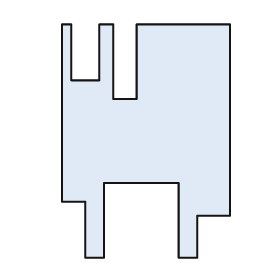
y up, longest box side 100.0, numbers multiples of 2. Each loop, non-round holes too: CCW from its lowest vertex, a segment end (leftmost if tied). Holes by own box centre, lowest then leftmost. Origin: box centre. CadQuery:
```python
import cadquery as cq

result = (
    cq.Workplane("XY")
    .moveTo(-26.0, -50.0)
    .lineTo(-18.0, -50.0)
    .lineTo(-18.0, -18.0)
    .lineTo(14.0, -18.0)
    .lineTo(14.0, -50.0)
    .lineTo(22.0, -50.0)
    .lineTo(22.0, -32.0)
    .lineTo(36.0, -32.0)
    .lineTo(36.0, 50.0)
    .lineTo(-4.0, 50.0)
    .lineTo(-4.0, 18.0)
    .lineTo(-14.0, 18.0)
    .lineTo(-14.0, 50.0)
    .lineTo(-20.0, 50.0)
    .lineTo(-20.0, 26.0)
    .lineTo(-32.0, 26.0)
    .lineTo(-32.0, 50.0)
    .lineTo(-36.0, 50.0)
    .lineTo(-36.0, -26.0)
    .lineTo(-26.0, -26.0)
    .close()
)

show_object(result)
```